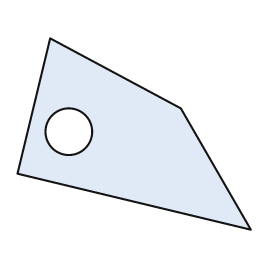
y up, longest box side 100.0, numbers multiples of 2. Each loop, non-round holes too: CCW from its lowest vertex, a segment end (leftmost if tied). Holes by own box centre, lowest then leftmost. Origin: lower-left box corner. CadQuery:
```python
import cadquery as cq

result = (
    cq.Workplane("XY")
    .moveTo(100.0, 0.0)
    .lineTo(70.0, 52.0)
    .lineTo(14.0, 82.0)
    .lineTo(0.0, 24.0)
    .close()
    .moveTo(22.0, 42.0)
    .circle(10.0)
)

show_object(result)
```